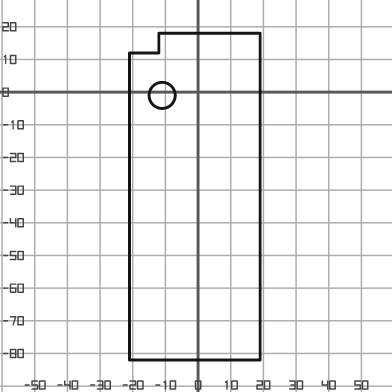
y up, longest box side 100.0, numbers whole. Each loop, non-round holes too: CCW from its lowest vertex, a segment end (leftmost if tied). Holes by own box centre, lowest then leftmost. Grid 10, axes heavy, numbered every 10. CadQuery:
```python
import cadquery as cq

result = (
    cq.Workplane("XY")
    .moveTo(-21.0, -82.0)
    .lineTo(19.0, -82.0)
    .lineTo(19.0, 18.0)
    .lineTo(-12.0, 18.0)
    .lineTo(-12.0, 12.0)
    .lineTo(-21.0, 12.0)
    .close()
    .moveTo(-11.0, -1.0)
    .circle(4.0)
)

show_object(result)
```